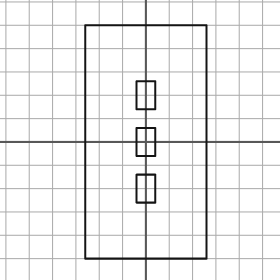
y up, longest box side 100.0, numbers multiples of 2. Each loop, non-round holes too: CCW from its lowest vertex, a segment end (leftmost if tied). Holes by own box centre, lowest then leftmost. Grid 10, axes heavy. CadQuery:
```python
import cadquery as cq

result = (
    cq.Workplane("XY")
    .moveTo(-26.0, -50.0)
    .lineTo(26.0, -50.0)
    .lineTo(26.0, 50.0)
    .lineTo(-26.0, 50.0)
    .close()
    .moveTo(-4.0, -26.0)
    .lineTo(4.0, -26.0)
    .lineTo(4.0, -14.0)
    .lineTo(-4.0, -14.0)
    .close()
    .moveTo(-4.0, -6.0)
    .lineTo(4.0, -6.0)
    .lineTo(4.0, 6.0)
    .lineTo(-4.0, 6.0)
    .close()
    .moveTo(-4.0, 14.0)
    .lineTo(4.0, 14.0)
    .lineTo(4.0, 26.0)
    .lineTo(-4.0, 26.0)
    .close()
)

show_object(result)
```